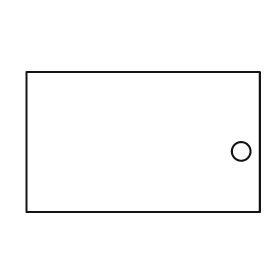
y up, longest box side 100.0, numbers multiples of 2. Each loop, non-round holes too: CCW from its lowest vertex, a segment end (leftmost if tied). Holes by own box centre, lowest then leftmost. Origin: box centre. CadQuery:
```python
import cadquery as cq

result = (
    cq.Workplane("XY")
    .moveTo(-50.0, -30.0)
    .lineTo(50.0, -30.0)
    .lineTo(50.0, 30.0)
    .lineTo(-50.0, 30.0)
    .close()
    .moveTo(42.0, -4.0)
    .circle(4.0)
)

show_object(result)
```